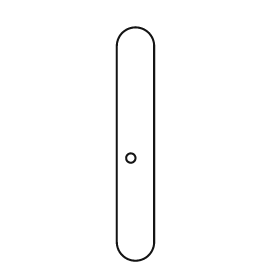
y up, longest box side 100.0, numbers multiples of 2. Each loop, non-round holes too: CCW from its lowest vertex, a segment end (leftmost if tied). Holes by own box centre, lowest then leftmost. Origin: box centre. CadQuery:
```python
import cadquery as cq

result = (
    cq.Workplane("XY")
    .moveTo(-8.0, -42.0)
    .threePointArc((0.0, -50.0), (8.0, -42.0))
    .lineTo(8.0, 42.0)
    .threePointArc((0.0, 50.0), (-8.0, 42.0))
    .close()
    .moveTo(-2.0, -6.0)
    .circle(2.0)
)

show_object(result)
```